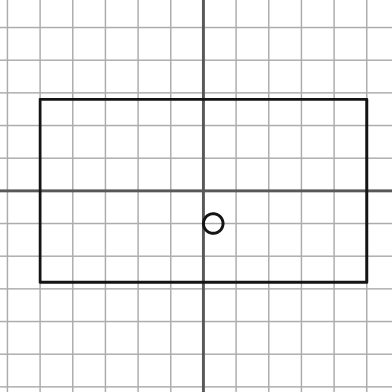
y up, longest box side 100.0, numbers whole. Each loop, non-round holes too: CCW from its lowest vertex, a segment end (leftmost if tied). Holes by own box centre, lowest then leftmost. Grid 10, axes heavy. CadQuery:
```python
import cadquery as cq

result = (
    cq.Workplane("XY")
    .moveTo(-50.0, -28.0)
    .lineTo(50.0, -28.0)
    .lineTo(50.0, 28.0)
    .lineTo(-50.0, 28.0)
    .close()
    .moveTo(3.0, -10.0)
    .circle(3.0)
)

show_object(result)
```